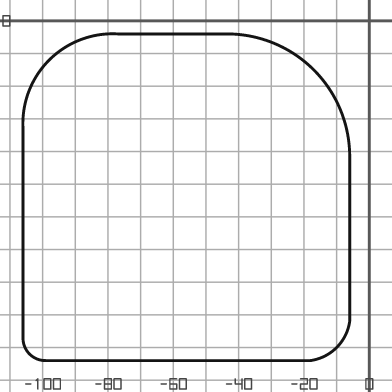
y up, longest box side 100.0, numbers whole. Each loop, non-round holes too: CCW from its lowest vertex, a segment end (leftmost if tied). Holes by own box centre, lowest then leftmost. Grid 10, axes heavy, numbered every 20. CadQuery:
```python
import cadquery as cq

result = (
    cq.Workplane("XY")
    .moveTo(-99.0, -104.0)
    .lineTo(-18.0, -104.0)
    .threePointArc((-10.0, -100.0), (-6.0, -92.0))
    .lineTo(-6.0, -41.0)
    .threePointArc((-17.0, -15.0), (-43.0, -4.0))
    .lineTo(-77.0, -4.0)
    .threePointArc((-98.0, -12.0), (-106.0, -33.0))
    .lineTo(-106.0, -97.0)
    .threePointArc((-104.0, -102.0), (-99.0, -104.0))
    .close()
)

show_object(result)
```